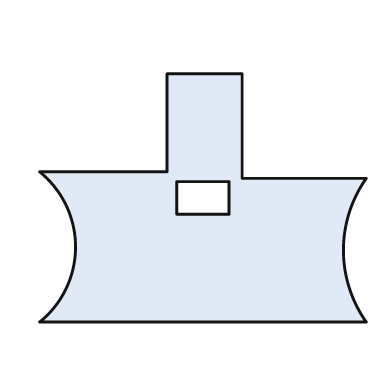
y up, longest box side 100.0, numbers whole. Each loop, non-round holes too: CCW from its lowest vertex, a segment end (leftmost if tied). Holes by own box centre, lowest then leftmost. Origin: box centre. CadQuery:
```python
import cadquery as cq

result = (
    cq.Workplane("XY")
    .moveTo(-50.0, -38.0)
    .lineTo(50.0, -38.0)
    .threePointArc((43.0, -16.0), (50.0, 6.0))
    .lineTo(12.0, 6.0)
    .lineTo(12.0, 38.0)
    .lineTo(-11.0, 38.0)
    .lineTo(-11.0, 8.0)
    .lineTo(-50.0, 8.0)
    .threePointArc((-39.0, -15.0), (-50.0, -38.0))
    .close()
    .moveTo(-8.0, -5.0)
    .lineTo(8.0, -5.0)
    .lineTo(8.0, 5.0)
    .lineTo(-8.0, 5.0)
    .close()
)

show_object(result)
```